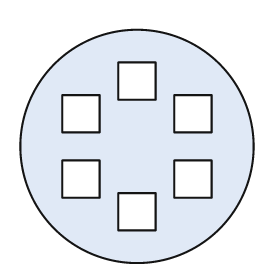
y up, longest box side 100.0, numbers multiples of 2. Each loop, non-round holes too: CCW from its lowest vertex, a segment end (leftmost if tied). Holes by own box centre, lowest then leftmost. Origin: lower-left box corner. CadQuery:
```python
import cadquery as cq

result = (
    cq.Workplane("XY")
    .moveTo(50.0, 50.0)
    .circle(50.0)
    .moveTo(42.0, 14.0)
    .lineTo(58.0, 14.0)
    .lineTo(58.0, 30.0)
    .lineTo(42.0, 30.0)
    .close()
    .moveTo(18.0, 28.0)
    .lineTo(34.0, 28.0)
    .lineTo(34.0, 44.0)
    .lineTo(18.0, 44.0)
    .close()
    .moveTo(66.0, 28.0)
    .lineTo(82.0, 28.0)
    .lineTo(82.0, 44.0)
    .lineTo(66.0, 44.0)
    .close()
    .moveTo(18.0, 56.0)
    .lineTo(34.0, 56.0)
    .lineTo(34.0, 72.0)
    .lineTo(18.0, 72.0)
    .close()
    .moveTo(66.0, 56.0)
    .lineTo(82.0, 56.0)
    .lineTo(82.0, 72.0)
    .lineTo(66.0, 72.0)
    .close()
    .moveTo(42.0, 70.0)
    .lineTo(58.0, 70.0)
    .lineTo(58.0, 86.0)
    .lineTo(42.0, 86.0)
    .close()
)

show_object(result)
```